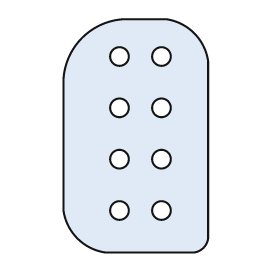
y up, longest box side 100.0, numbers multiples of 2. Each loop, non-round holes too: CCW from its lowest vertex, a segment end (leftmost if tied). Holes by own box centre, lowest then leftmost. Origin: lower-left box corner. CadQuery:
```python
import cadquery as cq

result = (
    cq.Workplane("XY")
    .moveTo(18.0, 0.0)
    .lineTo(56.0, 0.0)
    .threePointArc((60.0, 2.0), (62.0, 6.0))
    .lineTo(62.0, 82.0)
    .threePointArc((56.0, 94.0), (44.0, 100.0))
    .lineTo(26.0, 100.0)
    .threePointArc((8.0, 92.0), (0.0, 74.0))
    .lineTo(0.0, 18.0)
    .threePointArc((6.0, 6.0), (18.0, 0.0))
    .close()
    .moveTo(24.0, 18.0)
    .circle(4.0)
    .moveTo(42.0, 18.0)
    .circle(4.0)
    .moveTo(24.0, 40.0)
    .circle(4.0)
    .moveTo(42.0, 40.0)
    .circle(4.0)
    .moveTo(24.0, 62.0)
    .circle(4.0)
    .moveTo(42.0, 62.0)
    .circle(4.0)
    .moveTo(24.0, 84.0)
    .circle(4.0)
    .moveTo(42.0, 84.0)
    .circle(4.0)
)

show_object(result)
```